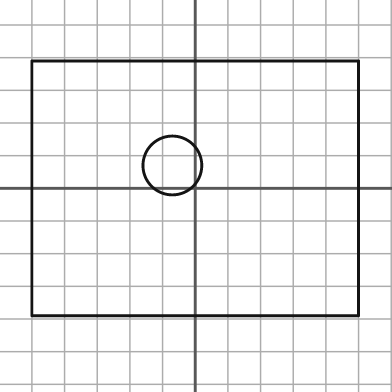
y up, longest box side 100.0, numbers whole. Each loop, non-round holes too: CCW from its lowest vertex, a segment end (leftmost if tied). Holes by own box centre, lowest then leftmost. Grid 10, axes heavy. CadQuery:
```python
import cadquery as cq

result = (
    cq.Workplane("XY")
    .moveTo(-50.0, -39.0)
    .lineTo(50.0, -39.0)
    .lineTo(50.0, 39.0)
    .lineTo(-50.0, 39.0)
    .close()
    .moveTo(-7.0, 7.0)
    .circle(9.0)
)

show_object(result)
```